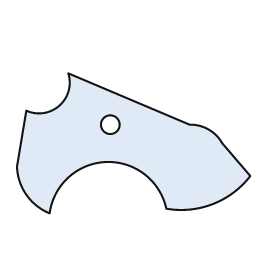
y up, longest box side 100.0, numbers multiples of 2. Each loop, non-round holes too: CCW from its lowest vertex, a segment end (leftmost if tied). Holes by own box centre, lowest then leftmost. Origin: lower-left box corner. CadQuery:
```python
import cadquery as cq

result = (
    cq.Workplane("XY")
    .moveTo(14.0, 0.0)
    .threePointArc((38.0, 22.0), (64.0, 2.0))
    .threePointArc((84.0, 4.0), (100.0, 16.0))
    .lineTo(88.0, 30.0)
    .threePointArc((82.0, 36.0), (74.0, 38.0))
    .lineTo(22.0, 60.0)
    .threePointArc((18.0, 46.0), (4.0, 44.0))
    .lineTo(0.0, 20.0)
    .threePointArc((4.0, 8.0), (14.0, 0.0))
    .close()
    .moveTo(40.0, 38.0)
    .circle(4.0)
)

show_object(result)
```